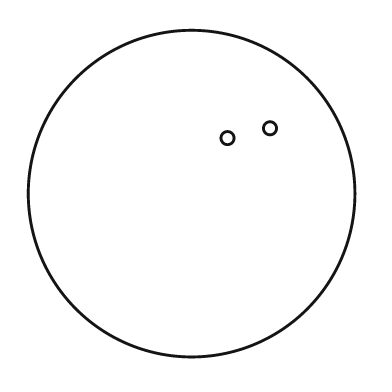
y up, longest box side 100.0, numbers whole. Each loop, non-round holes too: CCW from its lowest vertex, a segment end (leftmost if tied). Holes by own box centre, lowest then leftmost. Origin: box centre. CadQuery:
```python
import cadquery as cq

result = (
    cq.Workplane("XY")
    .moveTo(0.0, 0.0)
    .circle(50.0)
    .moveTo(11.0, 17.0)
    .circle(2.0)
    .moveTo(24.0, 20.0)
    .circle(2.0)
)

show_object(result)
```